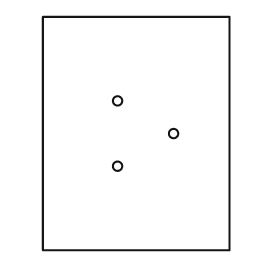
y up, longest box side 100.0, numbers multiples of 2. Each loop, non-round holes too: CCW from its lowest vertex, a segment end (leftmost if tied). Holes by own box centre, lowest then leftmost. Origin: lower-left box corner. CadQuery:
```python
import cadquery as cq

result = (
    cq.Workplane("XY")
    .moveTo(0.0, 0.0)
    .lineTo(80.0, 0.0)
    .lineTo(80.0, 100.0)
    .lineTo(0.0, 100.0)
    .close()
    .moveTo(32.0, 36.0)
    .circle(2.0)
    .moveTo(56.0, 50.0)
    .circle(2.0)
    .moveTo(32.0, 64.0)
    .circle(2.0)
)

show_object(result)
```